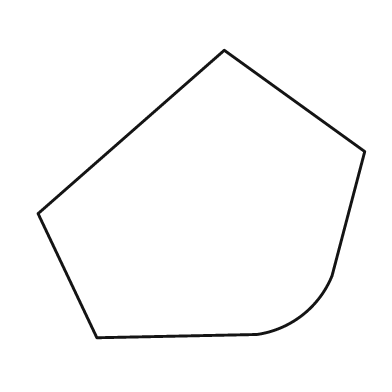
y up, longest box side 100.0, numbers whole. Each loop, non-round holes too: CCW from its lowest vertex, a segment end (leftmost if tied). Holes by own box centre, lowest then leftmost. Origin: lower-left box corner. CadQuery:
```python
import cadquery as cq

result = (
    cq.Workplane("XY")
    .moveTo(18.0, 0.0)
    .lineTo(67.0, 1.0)
    .threePointArc((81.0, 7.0), (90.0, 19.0))
    .lineTo(100.0, 57.0)
    .lineTo(57.0, 88.0)
    .lineTo(0.0, 38.0)
    .close()
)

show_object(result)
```